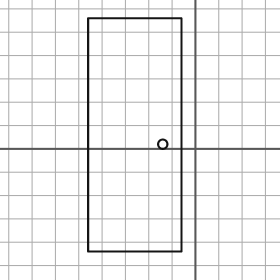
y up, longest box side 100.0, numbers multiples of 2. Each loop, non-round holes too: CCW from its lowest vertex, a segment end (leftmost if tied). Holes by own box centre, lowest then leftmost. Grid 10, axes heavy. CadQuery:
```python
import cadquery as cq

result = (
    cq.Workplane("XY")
    .moveTo(-46.0, -44.0)
    .lineTo(-6.0, -44.0)
    .lineTo(-6.0, 56.0)
    .lineTo(-46.0, 56.0)
    .close()
    .moveTo(-14.0, 2.0)
    .circle(2.0)
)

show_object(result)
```